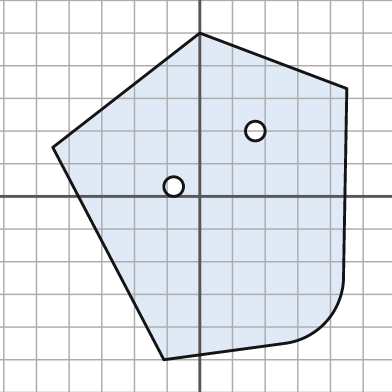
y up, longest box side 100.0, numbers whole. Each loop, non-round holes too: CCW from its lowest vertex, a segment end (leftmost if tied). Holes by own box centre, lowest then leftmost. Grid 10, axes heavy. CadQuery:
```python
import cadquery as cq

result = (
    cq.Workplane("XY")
    .moveTo(-11.0, -50.0)
    .lineTo(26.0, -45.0)
    .threePointArc((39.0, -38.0), (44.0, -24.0))
    .lineTo(45.0, 33.0)
    .lineTo(0.0, 50.0)
    .lineTo(-45.0, 15.0)
    .close()
    .moveTo(-8.0, 3.0)
    .circle(3.0)
    .moveTo(17.0, 20.0)
    .circle(3.0)
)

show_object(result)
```